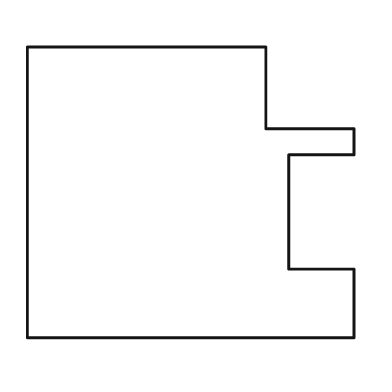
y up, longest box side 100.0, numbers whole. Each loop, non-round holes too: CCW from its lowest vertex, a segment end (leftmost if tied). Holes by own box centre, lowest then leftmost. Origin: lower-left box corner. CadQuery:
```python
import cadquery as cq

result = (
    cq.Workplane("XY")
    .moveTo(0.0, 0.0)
    .lineTo(100.0, 0.0)
    .lineTo(100.0, 21.0)
    .lineTo(80.0, 21.0)
    .lineTo(80.0, 56.0)
    .lineTo(100.0, 56.0)
    .lineTo(100.0, 64.0)
    .lineTo(73.0, 64.0)
    .lineTo(73.0, 89.0)
    .lineTo(0.0, 89.0)
    .close()
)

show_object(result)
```